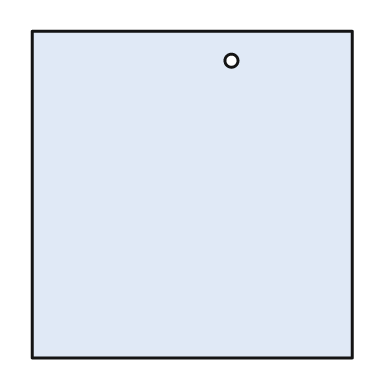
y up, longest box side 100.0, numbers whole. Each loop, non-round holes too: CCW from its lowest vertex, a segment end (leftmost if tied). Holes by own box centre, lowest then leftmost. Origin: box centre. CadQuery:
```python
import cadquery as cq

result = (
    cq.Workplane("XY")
    .moveTo(-49.0, -50.0)
    .lineTo(49.0, -50.0)
    .lineTo(49.0, 50.0)
    .lineTo(-49.0, 50.0)
    .close()
    .moveTo(12.0, 41.0)
    .circle(2.0)
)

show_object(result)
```